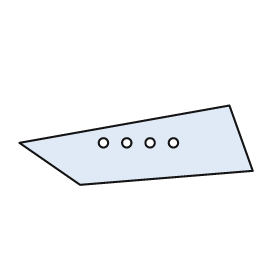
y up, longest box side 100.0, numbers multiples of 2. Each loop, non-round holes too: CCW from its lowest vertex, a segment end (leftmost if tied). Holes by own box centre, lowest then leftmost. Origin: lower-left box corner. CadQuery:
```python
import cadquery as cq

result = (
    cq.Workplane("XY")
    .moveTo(26.0, 0.0)
    .lineTo(100.0, 6.0)
    .lineTo(90.0, 34.0)
    .lineTo(0.0, 18.0)
    .close()
    .moveTo(36.0, 18.0)
    .circle(2.0)
    .moveTo(46.0, 18.0)
    .circle(2.0)
    .moveTo(56.0, 18.0)
    .circle(2.0)
    .moveTo(66.0, 18.0)
    .circle(2.0)
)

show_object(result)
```